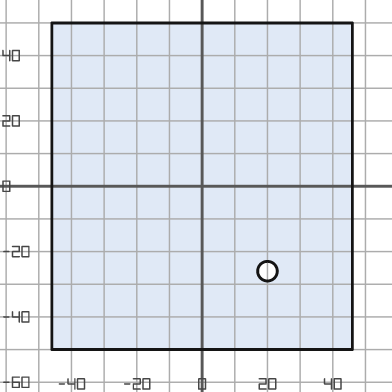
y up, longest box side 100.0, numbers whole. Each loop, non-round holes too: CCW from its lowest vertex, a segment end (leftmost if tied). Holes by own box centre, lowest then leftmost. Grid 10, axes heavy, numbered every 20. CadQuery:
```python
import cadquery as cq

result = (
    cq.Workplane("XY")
    .moveTo(-46.0, -50.0)
    .lineTo(46.0, -50.0)
    .lineTo(46.0, 50.0)
    .lineTo(-46.0, 50.0)
    .close()
    .moveTo(20.0, -26.0)
    .circle(3.0)
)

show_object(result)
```